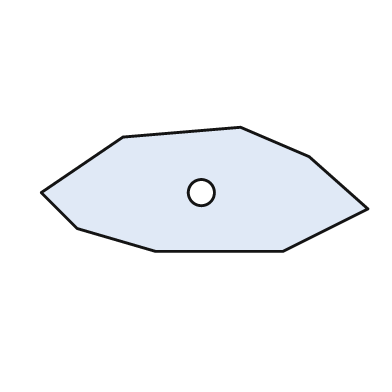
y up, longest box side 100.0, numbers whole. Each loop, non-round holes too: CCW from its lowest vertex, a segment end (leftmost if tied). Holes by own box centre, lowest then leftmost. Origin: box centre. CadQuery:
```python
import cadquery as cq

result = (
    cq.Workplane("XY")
    .moveTo(-15.0, -19.0)
    .lineTo(24.0, -19.0)
    .lineTo(50.0, -6.0)
    .lineTo(32.0, 10.0)
    .lineTo(11.0, 19.0)
    .lineTo(-25.0, 16.0)
    .lineTo(-50.0, -1.0)
    .lineTo(-39.0, -12.0)
    .close()
    .moveTo(-1.0, -1.0)
    .circle(4.0)
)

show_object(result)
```